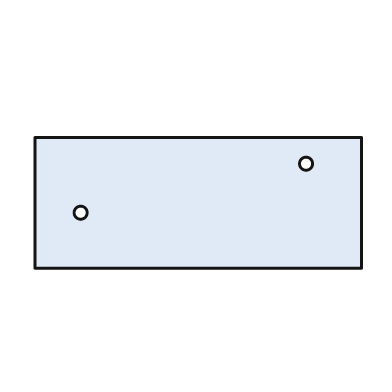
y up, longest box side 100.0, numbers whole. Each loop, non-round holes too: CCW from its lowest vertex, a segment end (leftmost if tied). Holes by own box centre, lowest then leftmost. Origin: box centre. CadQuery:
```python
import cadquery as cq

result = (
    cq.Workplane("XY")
    .moveTo(-50.0, -20.0)
    .lineTo(50.0, -20.0)
    .lineTo(50.0, 20.0)
    .lineTo(-50.0, 20.0)
    .close()
    .moveTo(-36.0, -3.0)
    .circle(2.0)
    .moveTo(33.0, 12.0)
    .circle(2.0)
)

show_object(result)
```